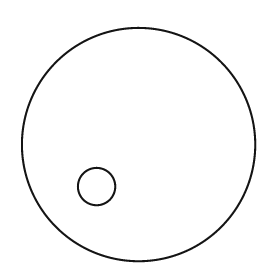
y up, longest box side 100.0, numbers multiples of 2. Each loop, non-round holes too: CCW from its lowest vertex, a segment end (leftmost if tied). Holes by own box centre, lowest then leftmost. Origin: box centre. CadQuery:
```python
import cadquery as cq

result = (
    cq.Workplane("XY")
    .moveTo(0.0, 0.0)
    .circle(50.0)
    .moveTo(-18.0, -18.0)
    .circle(8.0)
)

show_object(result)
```